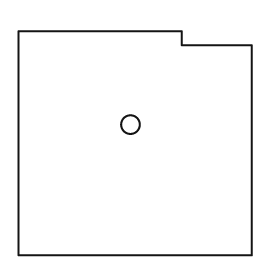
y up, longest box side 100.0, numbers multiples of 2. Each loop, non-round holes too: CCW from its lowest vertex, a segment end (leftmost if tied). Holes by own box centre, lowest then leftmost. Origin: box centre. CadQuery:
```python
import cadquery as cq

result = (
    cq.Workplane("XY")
    .moveTo(-50.0, -48.0)
    .lineTo(50.0, -48.0)
    .lineTo(50.0, 42.0)
    .lineTo(20.0, 42.0)
    .lineTo(20.0, 48.0)
    .lineTo(-50.0, 48.0)
    .close()
    .moveTo(-2.0, 8.0)
    .circle(4.0)
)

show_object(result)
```